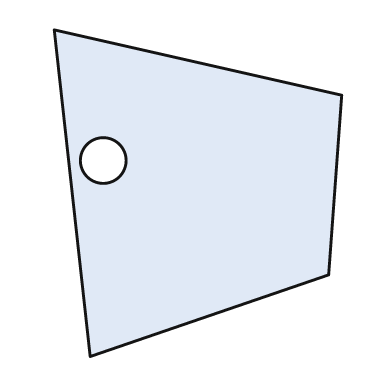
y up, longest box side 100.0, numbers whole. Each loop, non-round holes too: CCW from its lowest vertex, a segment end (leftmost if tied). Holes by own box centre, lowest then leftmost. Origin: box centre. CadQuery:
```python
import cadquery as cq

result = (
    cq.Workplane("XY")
    .moveTo(-33.0, -50.0)
    .lineTo(40.0, -25.0)
    .lineTo(44.0, 30.0)
    .lineTo(-44.0, 50.0)
    .close()
    .moveTo(-29.0, 10.0)
    .circle(7.0)
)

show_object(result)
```